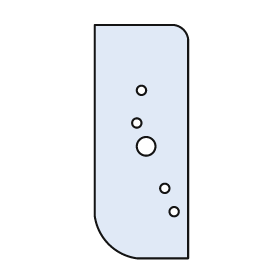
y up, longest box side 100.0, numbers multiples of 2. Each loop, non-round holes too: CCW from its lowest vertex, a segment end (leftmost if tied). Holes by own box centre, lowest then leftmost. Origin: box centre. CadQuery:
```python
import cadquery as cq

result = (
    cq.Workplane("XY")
    .moveTo(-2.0, -50.0)
    .lineTo(20.0, -50.0)
    .lineTo(20.0, 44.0)
    .threePointArc((18.0, 48.0), (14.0, 50.0))
    .lineTo(-20.0, 50.0)
    .lineTo(-20.0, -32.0)
    .threePointArc((-14.0, -44.0), (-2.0, -50.0))
    .close()
    .moveTo(14.0, -30.0)
    .circle(2.0)
    .moveTo(10.0, -20.0)
    .circle(2.0)
    .moveTo(2.0, -2.0)
    .circle(4.0)
    .moveTo(-2.0, 8.0)
    .circle(2.0)
    .moveTo(0.0, 22.0)
    .circle(2.0)
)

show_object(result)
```